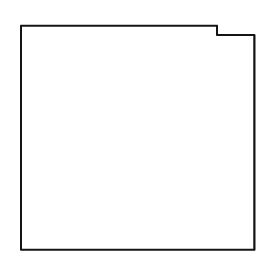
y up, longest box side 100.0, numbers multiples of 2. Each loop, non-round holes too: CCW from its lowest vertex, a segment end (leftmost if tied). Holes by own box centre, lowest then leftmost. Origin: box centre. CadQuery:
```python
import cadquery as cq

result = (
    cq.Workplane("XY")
    .moveTo(-50.0, -48.0)
    .lineTo(50.0, -48.0)
    .lineTo(50.0, 44.0)
    .lineTo(34.0, 44.0)
    .lineTo(34.0, 48.0)
    .lineTo(-50.0, 48.0)
    .close()
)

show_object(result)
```